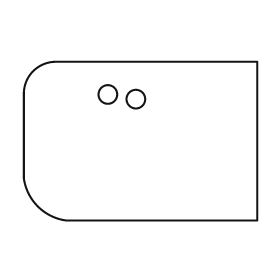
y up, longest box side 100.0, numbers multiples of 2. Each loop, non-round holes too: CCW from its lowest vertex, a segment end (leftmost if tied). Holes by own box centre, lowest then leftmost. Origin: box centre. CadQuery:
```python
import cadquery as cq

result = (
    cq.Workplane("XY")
    .moveTo(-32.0, -34.0)
    .lineTo(50.0, -34.0)
    .lineTo(50.0, 34.0)
    .lineTo(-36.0, 34.0)
    .threePointArc((-46.0, 30.0), (-50.0, 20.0))
    .lineTo(-50.0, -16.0)
    .threePointArc((-44.0, -28.0), (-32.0, -34.0))
    .close()
    .moveTo(-2.0, 18.0)
    .circle(4.0)
    .moveTo(-14.0, 20.0)
    .circle(4.0)
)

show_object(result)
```